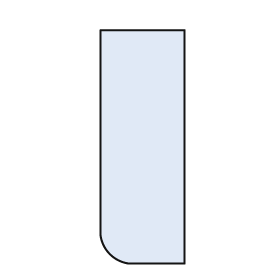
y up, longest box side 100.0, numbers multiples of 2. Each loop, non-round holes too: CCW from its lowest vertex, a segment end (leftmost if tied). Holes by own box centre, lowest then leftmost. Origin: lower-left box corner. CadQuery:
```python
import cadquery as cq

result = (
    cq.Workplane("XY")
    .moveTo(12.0, 0.0)
    .lineTo(36.0, 0.0)
    .lineTo(36.0, 100.0)
    .lineTo(0.0, 100.0)
    .lineTo(0.0, 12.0)
    .threePointArc((4.0, 4.0), (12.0, 0.0))
    .close()
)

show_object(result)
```